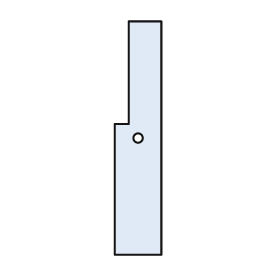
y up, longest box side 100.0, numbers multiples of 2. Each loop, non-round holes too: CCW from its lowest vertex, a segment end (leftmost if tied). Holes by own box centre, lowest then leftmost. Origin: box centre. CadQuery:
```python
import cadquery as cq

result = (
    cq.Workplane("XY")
    .moveTo(-10.0, -50.0)
    .lineTo(10.0, -50.0)
    .lineTo(10.0, 50.0)
    .lineTo(-4.0, 50.0)
    .lineTo(-4.0, 6.0)
    .lineTo(-10.0, 6.0)
    .close()
    .moveTo(0.0, 0.0)
    .circle(2.0)
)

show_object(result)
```